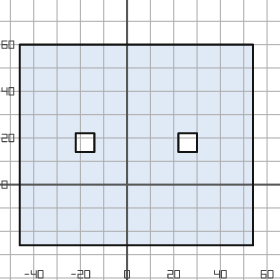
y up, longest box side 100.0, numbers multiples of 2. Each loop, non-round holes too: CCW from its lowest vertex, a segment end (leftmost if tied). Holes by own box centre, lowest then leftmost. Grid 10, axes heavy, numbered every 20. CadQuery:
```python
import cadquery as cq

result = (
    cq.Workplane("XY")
    .moveTo(-46.0, -26.0)
    .lineTo(54.0, -26.0)
    .lineTo(54.0, 60.0)
    .lineTo(-46.0, 60.0)
    .close()
    .moveTo(-22.0, 14.0)
    .lineTo(-14.0, 14.0)
    .lineTo(-14.0, 22.0)
    .lineTo(-22.0, 22.0)
    .close()
    .moveTo(22.0, 14.0)
    .lineTo(30.0, 14.0)
    .lineTo(30.0, 22.0)
    .lineTo(22.0, 22.0)
    .close()
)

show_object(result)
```